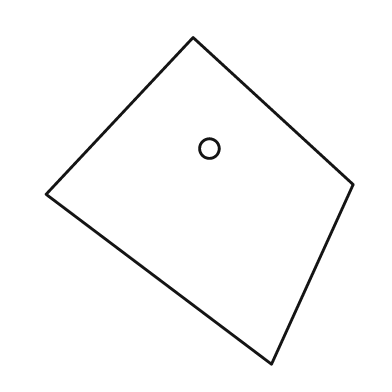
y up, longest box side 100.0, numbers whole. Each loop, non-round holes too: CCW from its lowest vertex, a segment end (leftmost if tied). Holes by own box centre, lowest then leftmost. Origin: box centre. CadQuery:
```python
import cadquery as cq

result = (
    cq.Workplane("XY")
    .moveTo(22.0, -50.0)
    .lineTo(47.0, 5.0)
    .lineTo(-2.0, 50.0)
    .lineTo(-47.0, 2.0)
    .close()
    .moveTo(3.0, 16.0)
    .circle(3.0)
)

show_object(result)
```